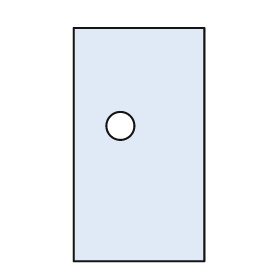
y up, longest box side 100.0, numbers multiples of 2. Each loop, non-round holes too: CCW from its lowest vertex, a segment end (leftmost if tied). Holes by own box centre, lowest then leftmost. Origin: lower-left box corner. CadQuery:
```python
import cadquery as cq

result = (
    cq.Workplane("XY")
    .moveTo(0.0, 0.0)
    .lineTo(56.0, 0.0)
    .lineTo(56.0, 100.0)
    .lineTo(0.0, 100.0)
    .close()
    .moveTo(20.0, 58.0)
    .circle(6.0)
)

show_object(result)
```